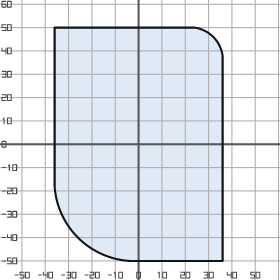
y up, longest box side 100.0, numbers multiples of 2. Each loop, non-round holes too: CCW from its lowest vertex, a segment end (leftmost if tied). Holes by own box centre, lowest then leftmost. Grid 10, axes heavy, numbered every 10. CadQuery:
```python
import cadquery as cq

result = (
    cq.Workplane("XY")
    .moveTo(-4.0, -50.0)
    .lineTo(36.0, -50.0)
    .lineTo(36.0, 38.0)
    .threePointArc((32.0, 46.0), (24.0, 50.0))
    .lineTo(-36.0, 50.0)
    .lineTo(-36.0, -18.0)
    .threePointArc((-26.0, -40.0), (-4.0, -50.0))
    .close()
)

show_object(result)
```